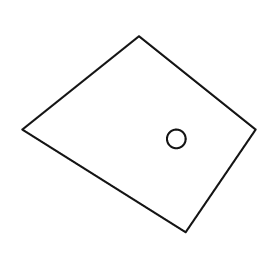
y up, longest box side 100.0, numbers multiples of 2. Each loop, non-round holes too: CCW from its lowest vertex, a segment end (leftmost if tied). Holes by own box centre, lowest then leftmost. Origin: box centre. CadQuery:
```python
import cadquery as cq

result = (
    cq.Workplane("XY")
    .moveTo(20.0, -42.0)
    .lineTo(50.0, 2.0)
    .lineTo(0.0, 42.0)
    .lineTo(-50.0, 2.0)
    .close()
    .moveTo(16.0, -2.0)
    .circle(4.0)
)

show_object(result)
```